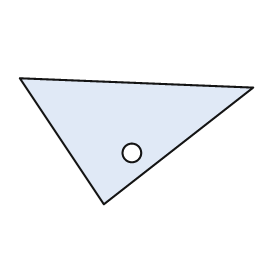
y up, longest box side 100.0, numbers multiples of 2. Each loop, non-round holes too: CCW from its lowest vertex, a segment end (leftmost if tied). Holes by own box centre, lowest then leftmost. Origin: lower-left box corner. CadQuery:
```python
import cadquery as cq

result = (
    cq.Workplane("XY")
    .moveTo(36.0, 0.0)
    .lineTo(100.0, 50.0)
    .lineTo(0.0, 54.0)
    .close()
    .moveTo(48.0, 22.0)
    .circle(4.0)
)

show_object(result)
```